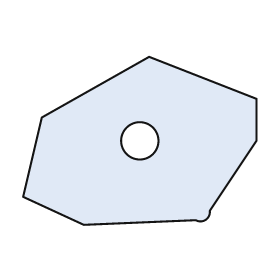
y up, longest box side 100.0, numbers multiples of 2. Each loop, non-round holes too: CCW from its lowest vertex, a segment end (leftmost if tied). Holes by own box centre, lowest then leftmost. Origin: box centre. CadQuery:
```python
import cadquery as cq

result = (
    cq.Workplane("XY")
    .moveTo(-24.0, -36.0)
    .lineTo(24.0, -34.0)
    .threePointArc((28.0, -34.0), (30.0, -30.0))
    .lineTo(50.0, 0.0)
    .lineTo(50.0, 18.0)
    .lineTo(4.0, 36.0)
    .lineTo(-42.0, 10.0)
    .lineTo(-50.0, -24.0)
    .close()
    .moveTo(0.0, 0.0)
    .circle(8.0)
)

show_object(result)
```